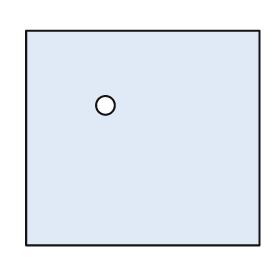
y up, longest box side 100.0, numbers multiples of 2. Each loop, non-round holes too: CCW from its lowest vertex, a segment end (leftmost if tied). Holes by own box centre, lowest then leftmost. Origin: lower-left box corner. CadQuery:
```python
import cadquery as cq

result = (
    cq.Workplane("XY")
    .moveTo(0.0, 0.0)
    .lineTo(100.0, 0.0)
    .lineTo(100.0, 92.0)
    .lineTo(0.0, 92.0)
    .close()
    .moveTo(34.0, 60.0)
    .circle(4.0)
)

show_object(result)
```